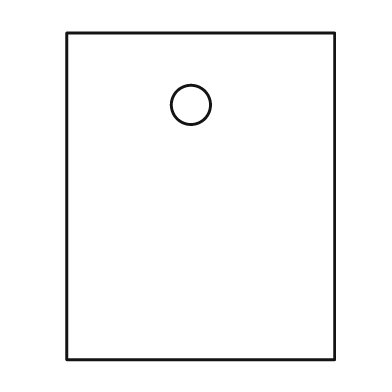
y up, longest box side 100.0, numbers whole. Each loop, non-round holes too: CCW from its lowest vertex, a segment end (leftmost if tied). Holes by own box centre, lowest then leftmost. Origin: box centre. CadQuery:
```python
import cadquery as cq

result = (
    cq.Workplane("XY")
    .moveTo(-41.0, -50.0)
    .lineTo(41.0, -50.0)
    .lineTo(41.0, 50.0)
    .lineTo(-41.0, 50.0)
    .close()
    .moveTo(-3.0, 28.0)
    .circle(6.0)
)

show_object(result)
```